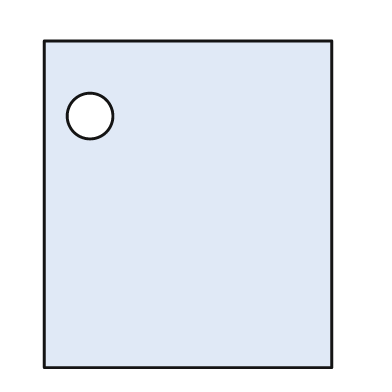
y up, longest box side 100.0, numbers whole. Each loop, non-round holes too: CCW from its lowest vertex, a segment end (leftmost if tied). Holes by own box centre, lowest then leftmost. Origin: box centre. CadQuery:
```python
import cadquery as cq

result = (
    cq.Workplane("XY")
    .moveTo(-44.0, -50.0)
    .lineTo(44.0, -50.0)
    .lineTo(44.0, 50.0)
    .lineTo(-44.0, 50.0)
    .close()
    .moveTo(-30.0, 27.0)
    .circle(7.0)
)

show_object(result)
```